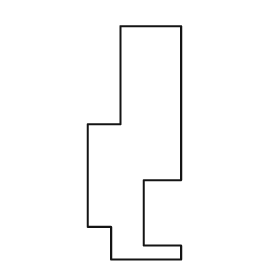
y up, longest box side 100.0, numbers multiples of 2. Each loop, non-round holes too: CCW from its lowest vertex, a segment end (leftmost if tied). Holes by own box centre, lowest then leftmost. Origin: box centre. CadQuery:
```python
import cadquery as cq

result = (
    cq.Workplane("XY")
    .moveTo(-10.0, -50.0)
    .lineTo(20.0, -50.0)
    .lineTo(20.0, -44.0)
    .lineTo(4.0, -44.0)
    .lineTo(4.0, -16.0)
    .lineTo(20.0, -16.0)
    .lineTo(20.0, 50.0)
    .lineTo(-6.0, 50.0)
    .lineTo(-6.0, 8.0)
    .lineTo(-20.0, 8.0)
    .lineTo(-20.0, -36.0)
    .lineTo(-10.0, -36.0)
    .close()
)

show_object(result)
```